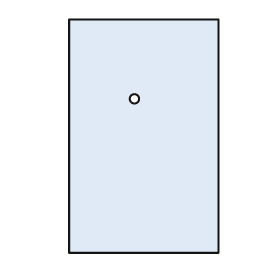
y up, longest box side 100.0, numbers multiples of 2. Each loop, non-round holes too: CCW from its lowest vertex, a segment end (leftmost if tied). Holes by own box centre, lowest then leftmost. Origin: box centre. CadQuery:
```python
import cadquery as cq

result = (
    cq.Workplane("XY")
    .moveTo(-32.0, -50.0)
    .lineTo(32.0, -50.0)
    .lineTo(32.0, 50.0)
    .lineTo(-32.0, 50.0)
    .close()
    .moveTo(-4.0, 16.0)
    .circle(2.0)
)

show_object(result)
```